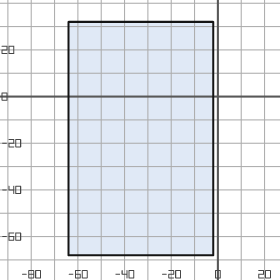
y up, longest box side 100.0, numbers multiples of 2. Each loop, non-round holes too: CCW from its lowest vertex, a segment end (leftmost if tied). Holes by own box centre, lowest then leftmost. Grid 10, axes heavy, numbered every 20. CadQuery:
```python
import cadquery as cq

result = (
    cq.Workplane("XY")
    .moveTo(-64.0, -68.0)
    .lineTo(-2.0, -68.0)
    .lineTo(-2.0, 32.0)
    .lineTo(-64.0, 32.0)
    .close()
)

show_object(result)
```